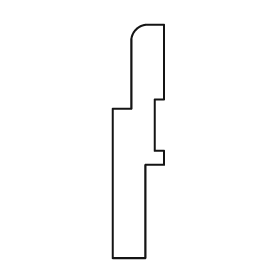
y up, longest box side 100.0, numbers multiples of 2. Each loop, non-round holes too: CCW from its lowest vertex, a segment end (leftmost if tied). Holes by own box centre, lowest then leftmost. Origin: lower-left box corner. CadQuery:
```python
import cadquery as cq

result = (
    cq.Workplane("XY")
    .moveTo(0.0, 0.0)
    .lineTo(14.0, 0.0)
    .lineTo(14.0, 40.0)
    .lineTo(22.0, 40.0)
    .lineTo(22.0, 46.0)
    .lineTo(18.0, 46.0)
    .lineTo(18.0, 68.0)
    .lineTo(22.0, 68.0)
    .lineTo(22.0, 100.0)
    .lineTo(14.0, 100.0)
    .threePointArc((10.0, 98.0), (8.0, 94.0))
    .lineTo(8.0, 64.0)
    .lineTo(0.0, 64.0)
    .close()
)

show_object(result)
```